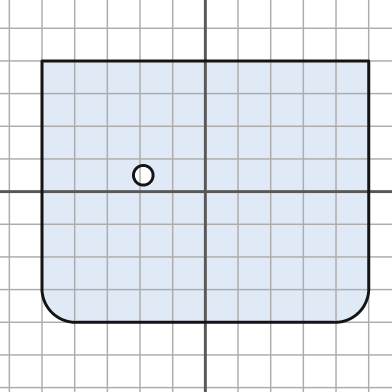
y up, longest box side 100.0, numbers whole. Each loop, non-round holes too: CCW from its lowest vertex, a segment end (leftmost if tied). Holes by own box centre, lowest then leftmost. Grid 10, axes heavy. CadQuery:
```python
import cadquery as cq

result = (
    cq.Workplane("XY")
    .moveTo(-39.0, -40.0)
    .lineTo(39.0, -40.0)
    .threePointArc((47.0, -37.0), (50.0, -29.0))
    .lineTo(50.0, 40.0)
    .lineTo(-50.0, 40.0)
    .lineTo(-50.0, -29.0)
    .threePointArc((-47.0, -37.0), (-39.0, -40.0))
    .close()
    .moveTo(-19.0, 5.0)
    .circle(3.0)
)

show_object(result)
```